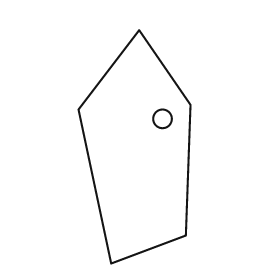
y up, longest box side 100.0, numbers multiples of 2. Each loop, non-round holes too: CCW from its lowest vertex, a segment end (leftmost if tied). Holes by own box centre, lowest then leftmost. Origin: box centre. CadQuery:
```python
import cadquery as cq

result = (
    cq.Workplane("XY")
    .moveTo(-10.0, -50.0)
    .lineTo(22.0, -38.0)
    .lineTo(24.0, 18.0)
    .lineTo(2.0, 50.0)
    .lineTo(-24.0, 16.0)
    .close()
    .moveTo(12.0, 12.0)
    .circle(4.0)
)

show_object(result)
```